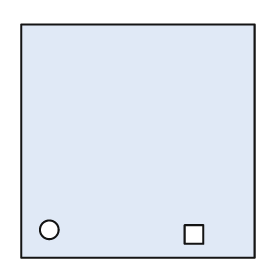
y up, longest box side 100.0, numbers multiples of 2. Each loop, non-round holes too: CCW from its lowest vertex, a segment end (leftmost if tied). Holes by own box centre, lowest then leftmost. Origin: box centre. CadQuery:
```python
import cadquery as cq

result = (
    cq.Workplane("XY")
    .moveTo(-50.0, -50.0)
    .lineTo(50.0, -50.0)
    .lineTo(50.0, 50.0)
    .lineTo(-50.0, 50.0)
    .close()
    .moveTo(20.0, -44.0)
    .lineTo(28.0, -44.0)
    .lineTo(28.0, -36.0)
    .lineTo(20.0, -36.0)
    .close()
    .moveTo(-38.0, -38.0)
    .circle(4.0)
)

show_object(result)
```